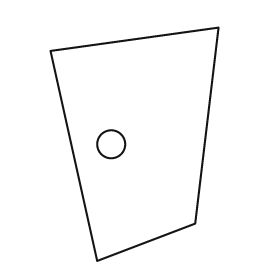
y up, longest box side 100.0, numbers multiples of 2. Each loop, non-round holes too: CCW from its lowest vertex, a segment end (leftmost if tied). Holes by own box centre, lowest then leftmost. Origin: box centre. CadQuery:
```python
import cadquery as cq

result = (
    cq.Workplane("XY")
    .moveTo(-16.0, -50.0)
    .lineTo(26.0, -34.0)
    .lineTo(36.0, 50.0)
    .lineTo(-36.0, 40.0)
    .close()
    .moveTo(-10.0, 0.0)
    .circle(6.0)
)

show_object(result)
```